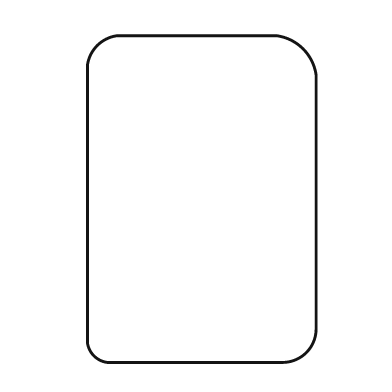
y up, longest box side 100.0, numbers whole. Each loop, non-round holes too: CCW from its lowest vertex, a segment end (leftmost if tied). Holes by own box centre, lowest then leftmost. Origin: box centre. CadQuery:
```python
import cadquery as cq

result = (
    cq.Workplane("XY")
    .moveTo(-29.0, -50.0)
    .lineTo(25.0, -50.0)
    .threePointArc((32.0, -47.0), (35.0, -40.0))
    .lineTo(35.0, 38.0)
    .threePointArc((31.0, 46.0), (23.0, 50.0))
    .lineTo(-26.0, 50.0)
    .threePointArc((-32.0, 47.0), (-35.0, 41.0))
    .lineTo(-35.0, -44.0)
    .threePointArc((-33.0, -48.0), (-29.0, -50.0))
    .close()
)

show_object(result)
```